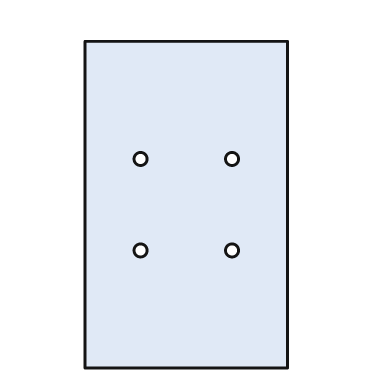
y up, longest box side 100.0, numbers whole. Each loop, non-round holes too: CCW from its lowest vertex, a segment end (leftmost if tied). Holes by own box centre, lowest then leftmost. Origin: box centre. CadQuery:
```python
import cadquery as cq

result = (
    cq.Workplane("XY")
    .moveTo(-31.0, -50.0)
    .lineTo(31.0, -50.0)
    .lineTo(31.0, 50.0)
    .lineTo(-31.0, 50.0)
    .close()
    .moveTo(-14.0, -14.0)
    .circle(2.0)
    .moveTo(14.0, -14.0)
    .circle(2.0)
    .moveTo(-14.0, 14.0)
    .circle(2.0)
    .moveTo(14.0, 14.0)
    .circle(2.0)
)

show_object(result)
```